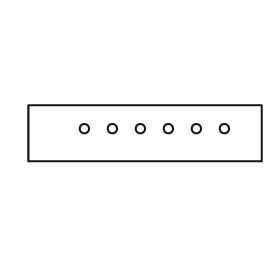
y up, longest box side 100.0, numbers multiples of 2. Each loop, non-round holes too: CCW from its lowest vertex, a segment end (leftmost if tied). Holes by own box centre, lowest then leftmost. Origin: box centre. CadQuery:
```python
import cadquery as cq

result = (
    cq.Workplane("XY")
    .moveTo(-50.0, -12.0)
    .lineTo(50.0, -12.0)
    .lineTo(50.0, 12.0)
    .lineTo(-50.0, 12.0)
    .close()
    .moveTo(-26.0, 2.0)
    .circle(2.0)
    .moveTo(-14.0, 2.0)
    .circle(2.0)
    .moveTo(-2.0, 2.0)
    .circle(2.0)
    .moveTo(10.0, 2.0)
    .circle(2.0)
    .moveTo(22.0, 2.0)
    .circle(2.0)
    .moveTo(34.0, 2.0)
    .circle(2.0)
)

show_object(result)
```